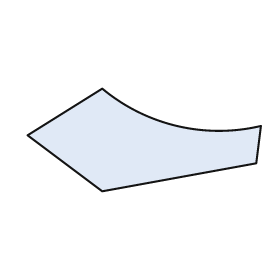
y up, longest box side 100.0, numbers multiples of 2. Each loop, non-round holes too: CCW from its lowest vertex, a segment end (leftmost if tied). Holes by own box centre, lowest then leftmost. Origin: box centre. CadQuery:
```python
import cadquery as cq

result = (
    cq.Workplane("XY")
    .moveTo(-18.0, -22.0)
    .lineTo(48.0, -10.0)
    .lineTo(50.0, 6.0)
    .threePointArc((14.0, 6.0), (-18.0, 22.0))
    .lineTo(-50.0, 2.0)
    .close()
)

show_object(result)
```